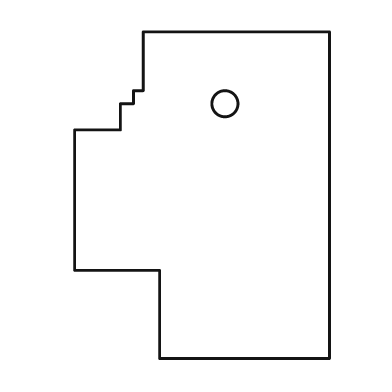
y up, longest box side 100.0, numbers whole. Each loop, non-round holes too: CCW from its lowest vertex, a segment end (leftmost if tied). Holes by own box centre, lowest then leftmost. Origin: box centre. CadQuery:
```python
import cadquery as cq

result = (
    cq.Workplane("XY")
    .moveTo(-13.0, -50.0)
    .lineTo(39.0, -50.0)
    .lineTo(39.0, 50.0)
    .lineTo(-18.0, 50.0)
    .lineTo(-18.0, 32.0)
    .lineTo(-21.0, 32.0)
    .lineTo(-21.0, 28.0)
    .lineTo(-25.0, 28.0)
    .lineTo(-25.0, 20.0)
    .lineTo(-39.0, 20.0)
    .lineTo(-39.0, -23.0)
    .lineTo(-13.0, -23.0)
    .close()
    .moveTo(7.0, 28.0)
    .circle(4.0)
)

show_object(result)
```